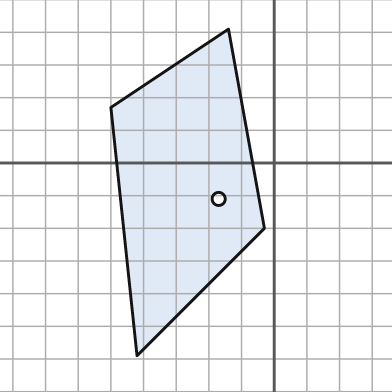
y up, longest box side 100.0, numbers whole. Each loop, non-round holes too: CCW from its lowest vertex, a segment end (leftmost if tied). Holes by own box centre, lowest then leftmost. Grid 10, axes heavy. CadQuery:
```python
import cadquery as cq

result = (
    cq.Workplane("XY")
    .moveTo(-42.0, -59.0)
    .lineTo(-3.0, -20.0)
    .lineTo(-14.0, 41.0)
    .lineTo(-50.0, 17.0)
    .close()
    .moveTo(-17.0, -11.0)
    .circle(2.0)
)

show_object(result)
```